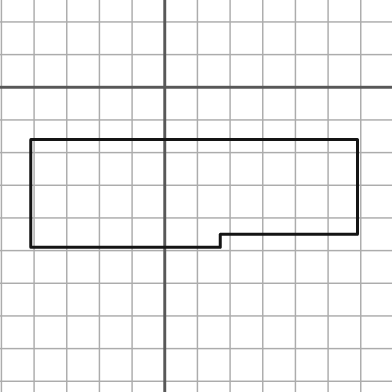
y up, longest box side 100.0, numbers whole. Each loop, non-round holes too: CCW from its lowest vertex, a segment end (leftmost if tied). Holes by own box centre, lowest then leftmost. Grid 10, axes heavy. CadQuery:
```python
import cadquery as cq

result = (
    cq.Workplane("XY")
    .moveTo(-41.0, -49.0)
    .lineTo(17.0, -49.0)
    .lineTo(17.0, -45.0)
    .lineTo(59.0, -45.0)
    .lineTo(59.0, -16.0)
    .lineTo(-41.0, -16.0)
    .close()
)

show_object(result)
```